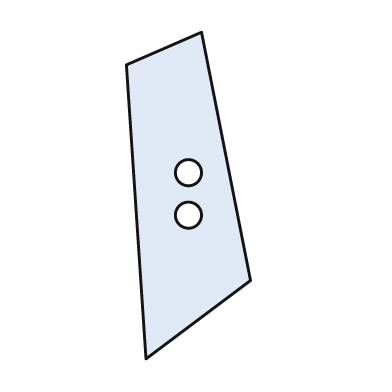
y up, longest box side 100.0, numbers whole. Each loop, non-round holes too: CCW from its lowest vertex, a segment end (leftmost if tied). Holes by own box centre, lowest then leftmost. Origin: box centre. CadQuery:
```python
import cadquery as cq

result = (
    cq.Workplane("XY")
    .moveTo(-13.0, -50.0)
    .lineTo(19.0, -26.0)
    .lineTo(4.0, 50.0)
    .lineTo(-19.0, 40.0)
    .close()
    .moveTo(0.0, -6.0)
    .circle(4.0)
    .moveTo(0.0, 7.0)
    .circle(4.0)
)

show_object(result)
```